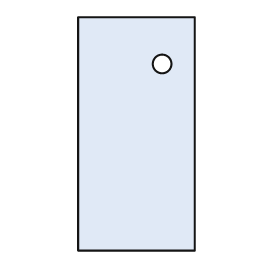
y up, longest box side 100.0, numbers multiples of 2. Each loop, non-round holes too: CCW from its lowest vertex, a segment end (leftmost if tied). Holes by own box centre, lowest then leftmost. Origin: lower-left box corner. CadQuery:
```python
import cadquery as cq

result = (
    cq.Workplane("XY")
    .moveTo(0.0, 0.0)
    .lineTo(50.0, 0.0)
    .lineTo(50.0, 100.0)
    .lineTo(0.0, 100.0)
    .close()
    .moveTo(36.0, 80.0)
    .circle(4.0)
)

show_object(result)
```